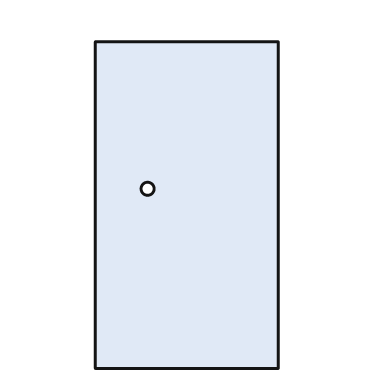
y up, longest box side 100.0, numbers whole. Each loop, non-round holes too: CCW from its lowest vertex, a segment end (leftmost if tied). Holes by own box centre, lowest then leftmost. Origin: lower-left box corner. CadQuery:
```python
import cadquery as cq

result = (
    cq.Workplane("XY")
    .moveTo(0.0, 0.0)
    .lineTo(56.0, 0.0)
    .lineTo(56.0, 100.0)
    .lineTo(0.0, 100.0)
    .close()
    .moveTo(16.0, 55.0)
    .circle(2.0)
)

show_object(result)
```